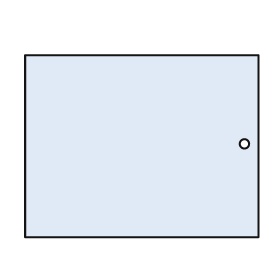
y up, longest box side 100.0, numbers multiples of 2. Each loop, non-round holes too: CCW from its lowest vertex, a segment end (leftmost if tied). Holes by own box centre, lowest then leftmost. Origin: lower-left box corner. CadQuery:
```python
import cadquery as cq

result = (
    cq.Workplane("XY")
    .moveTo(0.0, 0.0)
    .lineTo(100.0, 0.0)
    .lineTo(100.0, 78.0)
    .lineTo(0.0, 78.0)
    .close()
    .moveTo(94.0, 40.0)
    .circle(2.0)
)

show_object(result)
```